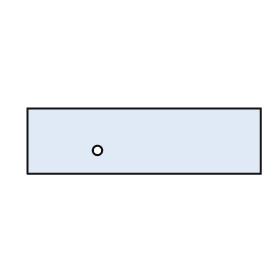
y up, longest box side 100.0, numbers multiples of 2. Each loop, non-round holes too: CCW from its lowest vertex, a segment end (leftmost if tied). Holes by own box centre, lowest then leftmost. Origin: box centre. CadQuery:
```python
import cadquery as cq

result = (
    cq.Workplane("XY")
    .moveTo(-50.0, -14.0)
    .lineTo(50.0, -14.0)
    .lineTo(50.0, 14.0)
    .lineTo(-50.0, 14.0)
    .close()
    .moveTo(-20.0, -4.0)
    .circle(2.0)
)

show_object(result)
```